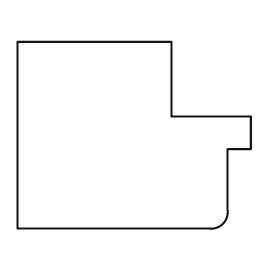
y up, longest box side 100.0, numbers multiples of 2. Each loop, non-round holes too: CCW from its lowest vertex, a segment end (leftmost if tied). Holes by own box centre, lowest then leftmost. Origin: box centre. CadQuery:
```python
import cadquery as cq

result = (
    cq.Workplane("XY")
    .moveTo(-50.0, -40.0)
    .lineTo(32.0, -40.0)
    .threePointArc((38.0, -38.0), (40.0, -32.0))
    .lineTo(40.0, -6.0)
    .lineTo(50.0, -6.0)
    .lineTo(50.0, 8.0)
    .lineTo(16.0, 8.0)
    .lineTo(16.0, 40.0)
    .lineTo(-50.0, 40.0)
    .close()
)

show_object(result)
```